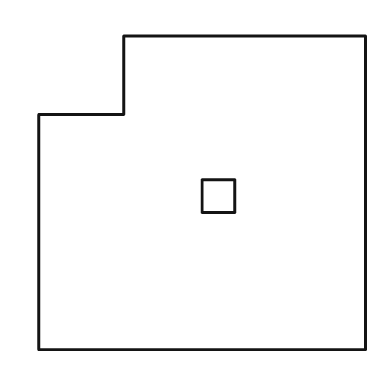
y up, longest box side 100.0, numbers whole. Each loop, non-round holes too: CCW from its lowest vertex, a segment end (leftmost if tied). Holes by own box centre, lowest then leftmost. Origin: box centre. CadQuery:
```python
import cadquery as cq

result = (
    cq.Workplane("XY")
    .moveTo(-50.0, -48.0)
    .lineTo(50.0, -48.0)
    .lineTo(50.0, 48.0)
    .lineTo(-24.0, 48.0)
    .lineTo(-24.0, 24.0)
    .lineTo(-50.0, 24.0)
    .close()
    .moveTo(0.0, -6.0)
    .lineTo(10.0, -6.0)
    .lineTo(10.0, 4.0)
    .lineTo(0.0, 4.0)
    .close()
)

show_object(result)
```